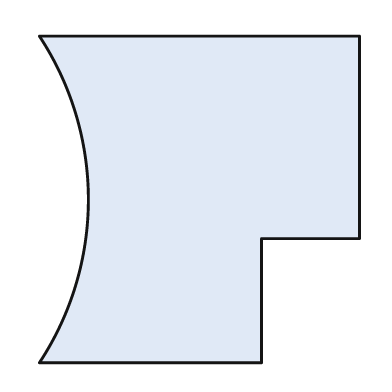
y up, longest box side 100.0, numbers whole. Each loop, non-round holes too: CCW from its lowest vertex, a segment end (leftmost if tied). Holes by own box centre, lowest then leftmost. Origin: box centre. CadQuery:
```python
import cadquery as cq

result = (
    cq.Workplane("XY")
    .moveTo(-49.0, -50.0)
    .lineTo(19.0, -50.0)
    .lineTo(19.0, -12.0)
    .lineTo(49.0, -12.0)
    .lineTo(49.0, 50.0)
    .lineTo(-49.0, 50.0)
    .threePointArc((-34.0, 0.0), (-49.0, -50.0))
    .close()
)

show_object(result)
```